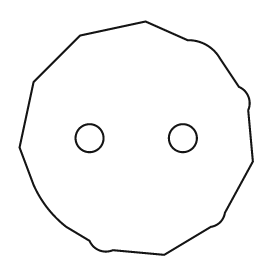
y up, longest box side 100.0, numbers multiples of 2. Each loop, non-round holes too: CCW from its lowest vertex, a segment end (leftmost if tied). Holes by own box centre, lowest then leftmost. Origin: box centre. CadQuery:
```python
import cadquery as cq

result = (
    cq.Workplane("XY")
    .moveTo(12.0, -50.0)
    .lineTo(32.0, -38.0)
    .threePointArc((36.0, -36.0), (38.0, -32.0))
    .lineTo(50.0, -10.0)
    .lineTo(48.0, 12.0)
    .threePointArc((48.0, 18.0), (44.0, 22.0))
    .lineTo(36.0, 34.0)
    .threePointArc((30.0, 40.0), (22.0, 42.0))
    .lineTo(4.0, 50.0)
    .lineTo(-24.0, 44.0)
    .lineTo(-44.0, 24.0)
    .lineTo(-50.0, -4.0)
    .lineTo(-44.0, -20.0)
    .threePointArc((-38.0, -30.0), (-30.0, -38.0))
    .lineTo(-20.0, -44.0)
    .threePointArc((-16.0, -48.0), (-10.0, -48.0))
    .close()
    .moveTo(-20.0, 0.0)
    .circle(6.0)
    .moveTo(20.0, 0.0)
    .circle(6.0)
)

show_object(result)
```